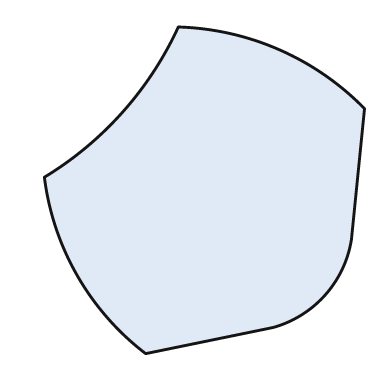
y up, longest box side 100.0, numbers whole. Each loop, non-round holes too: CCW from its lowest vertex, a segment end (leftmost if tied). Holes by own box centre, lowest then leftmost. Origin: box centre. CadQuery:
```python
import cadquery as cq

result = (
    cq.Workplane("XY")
    .moveTo(-18.0, -50.0)
    .lineTo(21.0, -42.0)
    .threePointArc((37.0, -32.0), (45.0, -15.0))
    .lineTo(49.0, 25.0)
    .threePointArc((23.0, 43.0), (-8.0, 50.0))
    .threePointArc((-25.0, 24.0), (-49.0, 4.0))
    .threePointArc((-39.0, -26.0), (-18.0, -50.0))
    .close()
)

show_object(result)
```